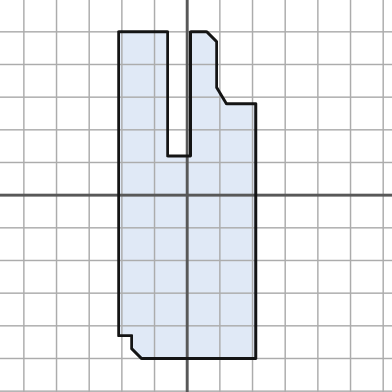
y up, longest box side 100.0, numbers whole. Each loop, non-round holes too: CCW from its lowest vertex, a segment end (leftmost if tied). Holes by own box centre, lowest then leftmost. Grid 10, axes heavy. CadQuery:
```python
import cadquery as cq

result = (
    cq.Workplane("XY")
    .moveTo(-14.0, -50.0)
    .lineTo(21.0, -50.0)
    .lineTo(21.0, 28.0)
    .lineTo(12.0, 28.0)
    .lineTo(9.0, 33.0)
    .lineTo(9.0, 47.0)
    .lineTo(6.0, 50.0)
    .lineTo(1.0, 50.0)
    .lineTo(1.0, 12.0)
    .lineTo(-6.0, 12.0)
    .lineTo(-6.0, 50.0)
    .lineTo(-21.0, 50.0)
    .lineTo(-21.0, -43.0)
    .lineTo(-17.0, -43.0)
    .lineTo(-17.0, -47.0)
    .close()
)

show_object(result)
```